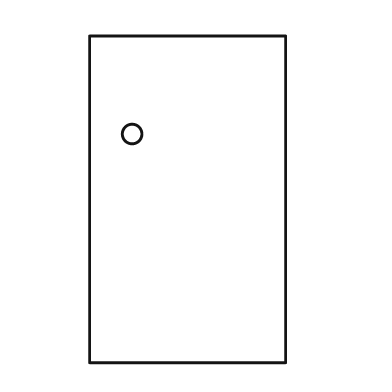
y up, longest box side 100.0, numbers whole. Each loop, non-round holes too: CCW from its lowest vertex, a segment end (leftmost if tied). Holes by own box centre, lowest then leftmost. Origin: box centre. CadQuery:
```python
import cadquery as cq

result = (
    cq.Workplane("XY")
    .moveTo(-30.0, -50.0)
    .lineTo(30.0, -50.0)
    .lineTo(30.0, 50.0)
    .lineTo(-30.0, 50.0)
    .close()
    .moveTo(-17.0, 20.0)
    .circle(3.0)
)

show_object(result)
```